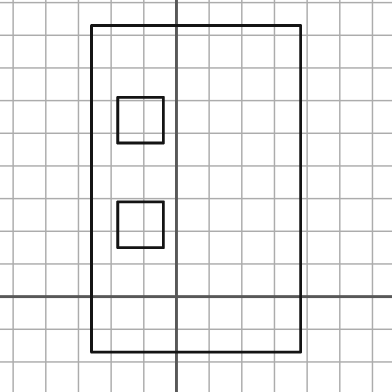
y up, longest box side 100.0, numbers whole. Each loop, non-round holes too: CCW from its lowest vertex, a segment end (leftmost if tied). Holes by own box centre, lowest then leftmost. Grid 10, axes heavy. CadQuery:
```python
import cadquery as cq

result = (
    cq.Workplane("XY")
    .moveTo(-26.0, -17.0)
    .lineTo(38.0, -17.0)
    .lineTo(38.0, 83.0)
    .lineTo(-26.0, 83.0)
    .close()
    .moveTo(-18.0, 15.0)
    .lineTo(-4.0, 15.0)
    .lineTo(-4.0, 29.0)
    .lineTo(-18.0, 29.0)
    .close()
    .moveTo(-18.0, 47.0)
    .lineTo(-4.0, 47.0)
    .lineTo(-4.0, 61.0)
    .lineTo(-18.0, 61.0)
    .close()
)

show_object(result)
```